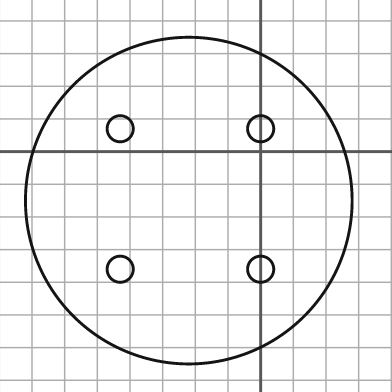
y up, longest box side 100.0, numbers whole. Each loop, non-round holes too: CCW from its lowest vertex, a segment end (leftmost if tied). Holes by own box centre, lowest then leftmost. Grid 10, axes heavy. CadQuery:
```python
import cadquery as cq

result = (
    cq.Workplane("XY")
    .moveTo(-22.0, -15.0)
    .circle(50.0)
    .moveTo(-43.0, -36.0)
    .circle(4.0)
    .moveTo(0.0, -36.0)
    .circle(4.0)
    .moveTo(-43.0, 7.0)
    .circle(4.0)
    .moveTo(0.0, 7.0)
    .circle(4.0)
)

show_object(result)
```